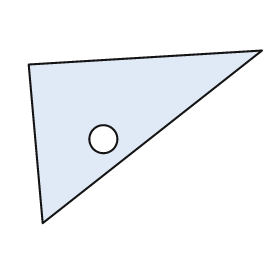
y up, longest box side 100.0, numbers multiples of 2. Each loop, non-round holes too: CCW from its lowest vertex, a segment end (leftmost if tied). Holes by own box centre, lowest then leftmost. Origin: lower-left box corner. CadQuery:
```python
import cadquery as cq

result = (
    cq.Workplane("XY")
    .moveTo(6.0, 0.0)
    .lineTo(100.0, 74.0)
    .lineTo(0.0, 68.0)
    .close()
    .moveTo(32.0, 36.0)
    .circle(6.0)
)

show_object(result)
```